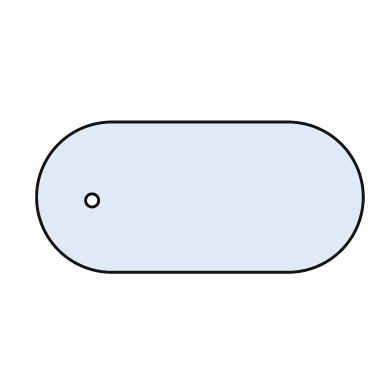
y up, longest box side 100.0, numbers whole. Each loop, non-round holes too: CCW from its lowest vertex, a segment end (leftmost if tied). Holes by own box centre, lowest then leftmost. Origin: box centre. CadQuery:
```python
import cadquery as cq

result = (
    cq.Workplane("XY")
    .moveTo(-27.0, -23.0)
    .lineTo(27.0, -23.0)
    .threePointArc((50.0, 0.0), (27.0, 23.0))
    .lineTo(-27.0, 23.0)
    .threePointArc((-50.0, 0.0), (-27.0, -23.0))
    .close()
    .moveTo(-33.0, -1.0)
    .circle(2.0)
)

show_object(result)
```